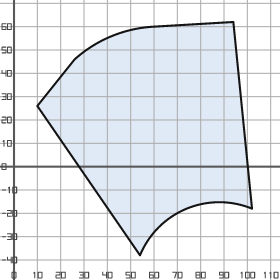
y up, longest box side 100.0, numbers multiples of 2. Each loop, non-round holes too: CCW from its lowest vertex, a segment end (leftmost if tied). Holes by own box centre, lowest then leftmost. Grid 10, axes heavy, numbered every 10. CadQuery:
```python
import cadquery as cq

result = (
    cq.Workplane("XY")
    .moveTo(54.0, -38.0)
    .threePointArc((74.0, -18.0), (102.0, -18.0))
    .lineTo(94.0, 62.0)
    .lineTo(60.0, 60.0)
    .threePointArc((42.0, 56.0), (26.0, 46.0))
    .lineTo(10.0, 26.0)
    .close()
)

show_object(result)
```